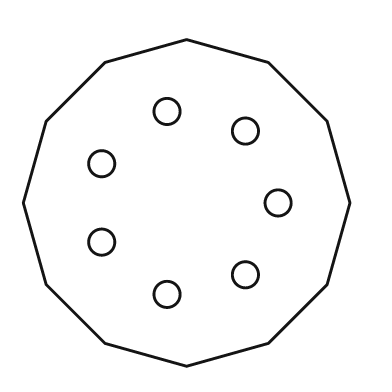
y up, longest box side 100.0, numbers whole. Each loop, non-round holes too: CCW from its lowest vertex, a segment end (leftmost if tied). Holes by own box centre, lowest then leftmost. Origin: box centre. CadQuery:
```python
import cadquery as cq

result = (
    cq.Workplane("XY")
    .moveTo(0.0, -50.0)
    .lineTo(25.0, -43.0)
    .lineTo(43.0, -25.0)
    .lineTo(50.0, 0.0)
    .lineTo(43.0, 25.0)
    .lineTo(25.0, 43.0)
    .lineTo(0.0, 50.0)
    .lineTo(-25.0, 43.0)
    .lineTo(-43.0, 25.0)
    .lineTo(-50.0, 0.0)
    .lineTo(-43.0, -25.0)
    .lineTo(-25.0, -43.0)
    .close()
    .moveTo(-6.0, -28.0)
    .circle(4.0)
    .moveTo(18.0, -22.0)
    .circle(4.0)
    .moveTo(-26.0, -12.0)
    .circle(4.0)
    .moveTo(28.0, 0.0)
    .circle(4.0)
    .moveTo(-26.0, 12.0)
    .circle(4.0)
    .moveTo(18.0, 22.0)
    .circle(4.0)
    .moveTo(-6.0, 28.0)
    .circle(4.0)
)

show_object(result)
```